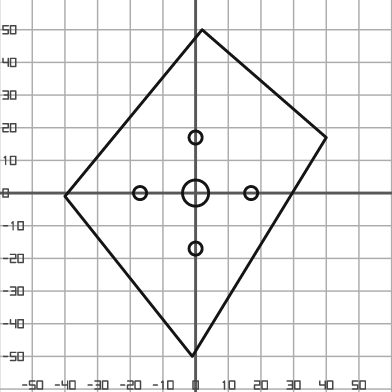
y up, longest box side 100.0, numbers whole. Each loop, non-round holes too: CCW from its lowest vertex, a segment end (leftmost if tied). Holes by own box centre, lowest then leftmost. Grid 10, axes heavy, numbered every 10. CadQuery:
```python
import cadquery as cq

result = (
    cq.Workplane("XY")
    .moveTo(-1.0, -50.0)
    .lineTo(40.0, 17.0)
    .lineTo(2.0, 50.0)
    .lineTo(-40.0, -1.0)
    .close()
    .moveTo(0.0, -17.0)
    .circle(2.0)
    .moveTo(-17.0, 0.0)
    .circle(2.0)
    .moveTo(0.0, 0.0)
    .circle(4.0)
    .moveTo(17.0, 0.0)
    .circle(2.0)
    .moveTo(0.0, 17.0)
    .circle(2.0)
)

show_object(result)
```